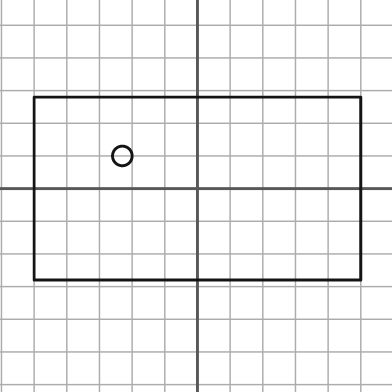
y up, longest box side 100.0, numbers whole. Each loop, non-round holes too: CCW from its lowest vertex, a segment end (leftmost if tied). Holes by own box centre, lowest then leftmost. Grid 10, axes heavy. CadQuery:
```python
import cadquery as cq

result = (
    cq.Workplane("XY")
    .moveTo(-50.0, -28.0)
    .lineTo(50.0, -28.0)
    .lineTo(50.0, 28.0)
    .lineTo(-50.0, 28.0)
    .close()
    .moveTo(-23.0, 10.0)
    .circle(3.0)
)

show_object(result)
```